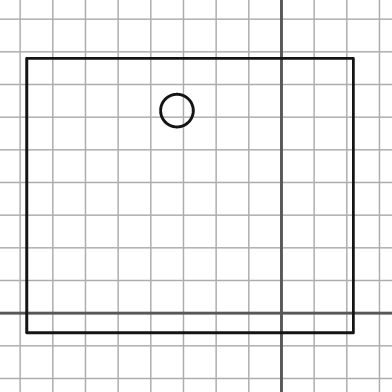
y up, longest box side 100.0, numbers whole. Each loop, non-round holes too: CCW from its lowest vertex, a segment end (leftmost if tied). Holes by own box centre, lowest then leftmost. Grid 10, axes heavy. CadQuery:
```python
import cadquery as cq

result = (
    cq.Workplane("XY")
    .moveTo(-78.0, -6.0)
    .lineTo(22.0, -6.0)
    .lineTo(22.0, 78.0)
    .lineTo(-78.0, 78.0)
    .close()
    .moveTo(-32.0, 62.0)
    .circle(5.0)
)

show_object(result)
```